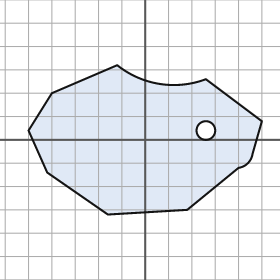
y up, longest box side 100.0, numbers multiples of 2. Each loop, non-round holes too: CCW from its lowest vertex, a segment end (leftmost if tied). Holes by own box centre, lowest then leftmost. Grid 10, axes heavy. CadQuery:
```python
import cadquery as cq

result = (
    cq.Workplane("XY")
    .moveTo(-16.0, -32.0)
    .lineTo(18.0, -30.0)
    .lineTo(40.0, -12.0)
    .threePointArc((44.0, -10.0), (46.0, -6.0))
    .lineTo(50.0, 8.0)
    .lineTo(26.0, 26.0)
    .threePointArc((6.0, 24.0), (-12.0, 32.0))
    .lineTo(-40.0, 20.0)
    .lineTo(-50.0, 4.0)
    .lineTo(-42.0, -14.0)
    .close()
    .moveTo(26.0, 4.0)
    .circle(4.0)
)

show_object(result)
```